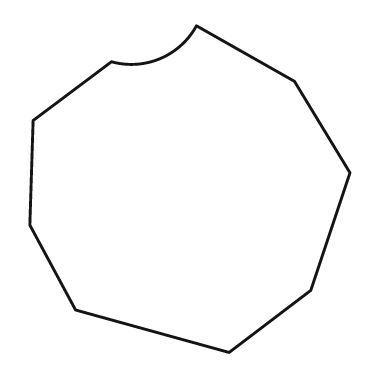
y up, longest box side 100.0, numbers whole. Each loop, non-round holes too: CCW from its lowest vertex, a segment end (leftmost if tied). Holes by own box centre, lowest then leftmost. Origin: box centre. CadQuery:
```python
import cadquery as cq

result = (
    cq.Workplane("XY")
    .moveTo(12.0, -50.0)
    .lineTo(37.0, -31.0)
    .lineTo(49.0, 5.0)
    .lineTo(32.0, 33.0)
    .lineTo(2.0, 50.0)
    .threePointArc((-9.0, 40.0), (-24.0, 39.0))
    .lineTo(-48.0, 21.0)
    .lineTo(-49.0, -11.0)
    .lineTo(-35.0, -37.0)
    .close()
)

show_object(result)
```